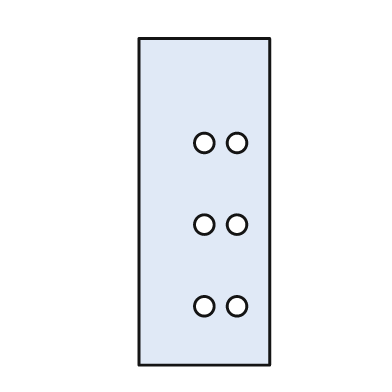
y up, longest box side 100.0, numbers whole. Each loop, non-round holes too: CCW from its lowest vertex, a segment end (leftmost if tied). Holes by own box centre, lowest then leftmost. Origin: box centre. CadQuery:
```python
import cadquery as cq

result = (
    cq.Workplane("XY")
    .moveTo(-20.0, -50.0)
    .lineTo(20.0, -50.0)
    .lineTo(20.0, 50.0)
    .lineTo(-20.0, 50.0)
    .close()
    .moveTo(0.0, -32.0)
    .circle(3.0)
    .moveTo(10.0, -32.0)
    .circle(3.0)
    .moveTo(0.0, -7.0)
    .circle(3.0)
    .moveTo(10.0, -7.0)
    .circle(3.0)
    .moveTo(0.0, 18.0)
    .circle(3.0)
    .moveTo(10.0, 18.0)
    .circle(3.0)
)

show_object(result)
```